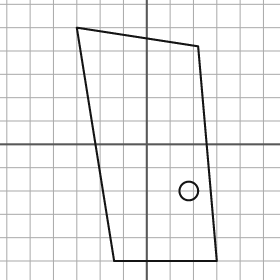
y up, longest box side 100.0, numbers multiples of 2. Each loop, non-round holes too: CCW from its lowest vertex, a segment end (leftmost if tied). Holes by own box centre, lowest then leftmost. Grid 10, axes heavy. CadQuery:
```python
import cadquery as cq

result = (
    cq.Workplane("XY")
    .moveTo(-14.0, -50.0)
    .lineTo(30.0, -50.0)
    .lineTo(22.0, 42.0)
    .lineTo(-30.0, 50.0)
    .close()
    .moveTo(18.0, -20.0)
    .circle(4.0)
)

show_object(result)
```